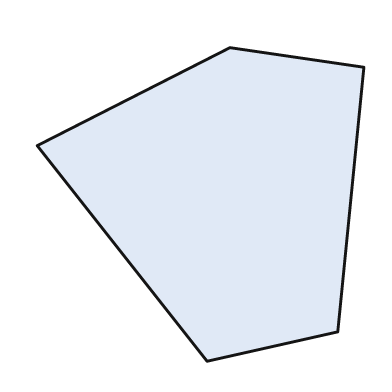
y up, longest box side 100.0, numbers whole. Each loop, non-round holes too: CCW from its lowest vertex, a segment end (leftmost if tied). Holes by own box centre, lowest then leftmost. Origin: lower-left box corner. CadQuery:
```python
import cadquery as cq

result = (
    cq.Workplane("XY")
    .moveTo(52.0, 0.0)
    .lineTo(92.0, 9.0)
    .lineTo(100.0, 90.0)
    .lineTo(59.0, 96.0)
    .lineTo(0.0, 66.0)
    .close()
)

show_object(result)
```